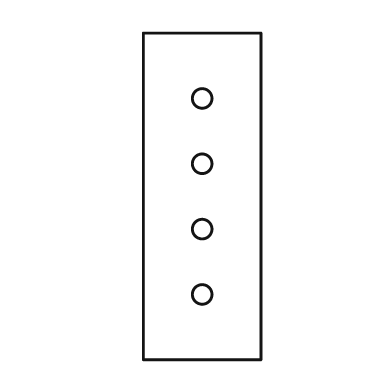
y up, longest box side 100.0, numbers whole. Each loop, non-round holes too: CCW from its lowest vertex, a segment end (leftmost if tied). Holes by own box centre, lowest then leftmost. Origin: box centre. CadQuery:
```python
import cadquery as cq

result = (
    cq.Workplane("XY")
    .moveTo(-18.0, -50.0)
    .lineTo(18.0, -50.0)
    .lineTo(18.0, 50.0)
    .lineTo(-18.0, 50.0)
    .close()
    .moveTo(0.0, -30.0)
    .circle(3.0)
    .moveTo(0.0, -10.0)
    .circle(3.0)
    .moveTo(0.0, 10.0)
    .circle(3.0)
    .moveTo(0.0, 30.0)
    .circle(3.0)
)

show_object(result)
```